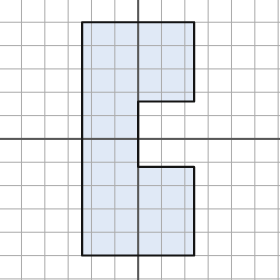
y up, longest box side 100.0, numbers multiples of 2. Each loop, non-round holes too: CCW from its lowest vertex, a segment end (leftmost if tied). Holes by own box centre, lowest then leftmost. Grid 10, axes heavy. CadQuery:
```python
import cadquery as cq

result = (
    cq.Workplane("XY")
    .moveTo(-24.0, -50.0)
    .lineTo(24.0, -50.0)
    .lineTo(24.0, -12.0)
    .lineTo(0.0, -12.0)
    .lineTo(0.0, 16.0)
    .lineTo(24.0, 16.0)
    .lineTo(24.0, 50.0)
    .lineTo(-24.0, 50.0)
    .close()
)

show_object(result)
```